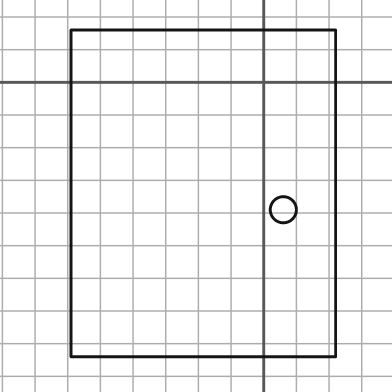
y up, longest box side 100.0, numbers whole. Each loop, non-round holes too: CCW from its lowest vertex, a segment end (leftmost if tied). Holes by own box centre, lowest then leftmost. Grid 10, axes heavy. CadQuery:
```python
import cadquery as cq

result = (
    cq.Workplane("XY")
    .moveTo(-59.0, -84.0)
    .lineTo(22.0, -84.0)
    .lineTo(22.0, 16.0)
    .lineTo(-59.0, 16.0)
    .close()
    .moveTo(6.0, -39.0)
    .circle(4.0)
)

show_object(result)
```